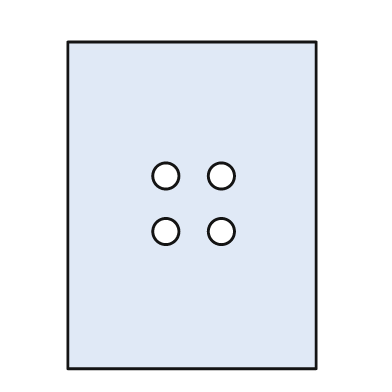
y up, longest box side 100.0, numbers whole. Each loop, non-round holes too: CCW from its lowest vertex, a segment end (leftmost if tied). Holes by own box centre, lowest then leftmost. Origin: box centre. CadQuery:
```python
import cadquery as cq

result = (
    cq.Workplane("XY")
    .moveTo(-38.0, -50.0)
    .lineTo(38.0, -50.0)
    .lineTo(38.0, 50.0)
    .lineTo(-38.0, 50.0)
    .close()
    .moveTo(-8.0, -8.0)
    .circle(4.0)
    .moveTo(9.0, -8.0)
    .circle(4.0)
    .moveTo(-8.0, 9.0)
    .circle(4.0)
    .moveTo(9.0, 9.0)
    .circle(4.0)
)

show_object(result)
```